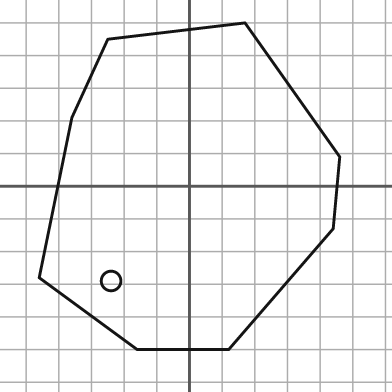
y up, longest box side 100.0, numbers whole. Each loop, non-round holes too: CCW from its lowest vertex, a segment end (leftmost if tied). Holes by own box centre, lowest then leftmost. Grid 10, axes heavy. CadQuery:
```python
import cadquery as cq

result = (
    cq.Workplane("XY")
    .moveTo(-16.0, -50.0)
    .lineTo(12.0, -50.0)
    .lineTo(44.0, -13.0)
    .lineTo(46.0, 9.0)
    .lineTo(17.0, 50.0)
    .lineTo(-25.0, 45.0)
    .lineTo(-36.0, 21.0)
    .lineTo(-46.0, -28.0)
    .close()
    .moveTo(-24.0, -29.0)
    .circle(3.0)
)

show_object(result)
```